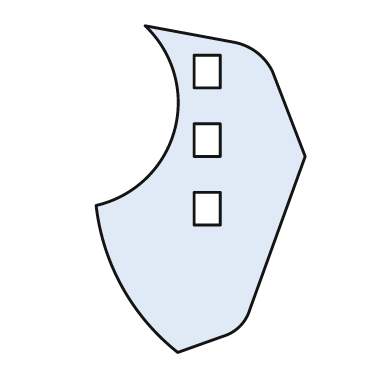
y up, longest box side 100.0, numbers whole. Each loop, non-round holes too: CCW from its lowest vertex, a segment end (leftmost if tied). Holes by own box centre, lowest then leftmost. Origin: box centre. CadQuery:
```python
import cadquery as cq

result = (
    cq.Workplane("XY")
    .moveTo(-7.0, -50.0)
    .lineTo(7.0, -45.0)
    .threePointArc((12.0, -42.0), (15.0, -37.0))
    .lineTo(32.0, 10.0)
    .lineTo(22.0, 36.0)
    .threePointArc((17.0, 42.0), (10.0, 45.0))
    .lineTo(-17.0, 50.0)
    .threePointArc((-8.0, 18.0), (-32.0, -5.0))
    .threePointArc((-24.0, -30.0), (-7.0, -50.0))
    .close()
    .moveTo(-2.0, -11.0)
    .lineTo(6.0, -11.0)
    .lineTo(6.0, -1.0)
    .lineTo(-2.0, -1.0)
    .close()
    .moveTo(-2.0, 10.0)
    .lineTo(6.0, 10.0)
    .lineTo(6.0, 20.0)
    .lineTo(-2.0, 20.0)
    .close()
    .moveTo(-2.0, 31.0)
    .lineTo(6.0, 31.0)
    .lineTo(6.0, 41.0)
    .lineTo(-2.0, 41.0)
    .close()
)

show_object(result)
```